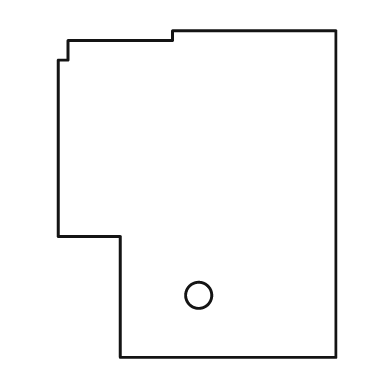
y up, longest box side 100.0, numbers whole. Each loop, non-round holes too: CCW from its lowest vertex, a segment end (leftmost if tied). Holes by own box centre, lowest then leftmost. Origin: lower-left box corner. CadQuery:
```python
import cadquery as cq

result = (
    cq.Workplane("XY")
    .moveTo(19.0, 0.0)
    .lineTo(85.0, 0.0)
    .lineTo(85.0, 100.0)
    .lineTo(35.0, 100.0)
    .lineTo(35.0, 97.0)
    .lineTo(3.0, 97.0)
    .lineTo(3.0, 91.0)
    .lineTo(0.0, 91.0)
    .lineTo(0.0, 37.0)
    .lineTo(19.0, 37.0)
    .close()
    .moveTo(43.0, 19.0)
    .circle(4.0)
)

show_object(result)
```